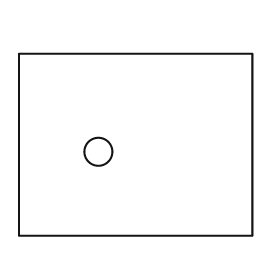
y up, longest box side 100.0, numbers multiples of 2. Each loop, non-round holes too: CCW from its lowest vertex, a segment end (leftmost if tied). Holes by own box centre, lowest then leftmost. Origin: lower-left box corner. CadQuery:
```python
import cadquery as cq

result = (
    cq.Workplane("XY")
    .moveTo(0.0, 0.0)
    .lineTo(100.0, 0.0)
    .lineTo(100.0, 78.0)
    .lineTo(0.0, 78.0)
    .close()
    .moveTo(34.0, 36.0)
    .circle(6.0)
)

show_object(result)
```